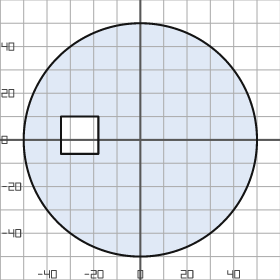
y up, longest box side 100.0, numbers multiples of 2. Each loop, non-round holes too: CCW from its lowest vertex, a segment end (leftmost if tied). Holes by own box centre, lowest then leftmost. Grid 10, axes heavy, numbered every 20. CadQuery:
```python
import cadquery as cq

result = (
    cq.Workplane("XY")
    .moveTo(0.0, 0.0)
    .circle(50.0)
    .moveTo(-34.0, -6.0)
    .lineTo(-18.0, -6.0)
    .lineTo(-18.0, 10.0)
    .lineTo(-34.0, 10.0)
    .close()
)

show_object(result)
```